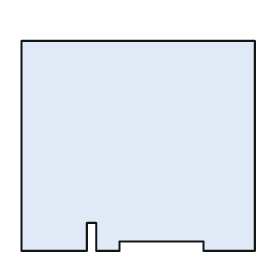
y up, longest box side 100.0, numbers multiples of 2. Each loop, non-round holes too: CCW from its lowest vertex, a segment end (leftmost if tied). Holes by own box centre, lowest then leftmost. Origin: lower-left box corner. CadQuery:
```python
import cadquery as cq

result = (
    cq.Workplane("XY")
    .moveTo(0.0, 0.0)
    .lineTo(28.0, 0.0)
    .lineTo(28.0, 12.0)
    .lineTo(32.0, 12.0)
    .lineTo(32.0, 0.0)
    .lineTo(42.0, 0.0)
    .lineTo(42.0, 4.0)
    .lineTo(78.0, 4.0)
    .lineTo(78.0, 0.0)
    .lineTo(100.0, 0.0)
    .lineTo(100.0, 90.0)
    .lineTo(0.0, 90.0)
    .close()
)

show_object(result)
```